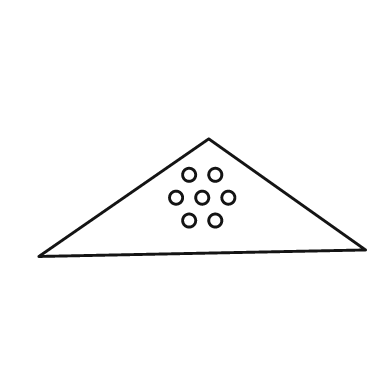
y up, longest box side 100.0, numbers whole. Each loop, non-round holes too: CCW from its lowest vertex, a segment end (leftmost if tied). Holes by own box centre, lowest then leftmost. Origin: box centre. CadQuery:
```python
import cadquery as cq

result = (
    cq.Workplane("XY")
    .moveTo(-50.0, -18.0)
    .lineTo(50.0, -16.0)
    .lineTo(2.0, 18.0)
    .close()
    .moveTo(-4.0, -7.0)
    .circle(2.0)
    .moveTo(4.0, -7.0)
    .circle(2.0)
    .moveTo(-8.0, 0.0)
    .circle(2.0)
    .moveTo(0.0, 0.0)
    .circle(2.0)
    .moveTo(8.0, 0.0)
    .circle(2.0)
    .moveTo(-4.0, 7.0)
    .circle(2.0)
    .moveTo(4.0, 7.0)
    .circle(2.0)
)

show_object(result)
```